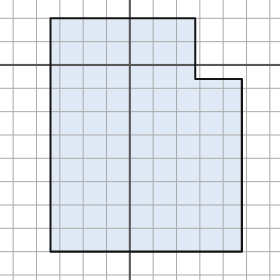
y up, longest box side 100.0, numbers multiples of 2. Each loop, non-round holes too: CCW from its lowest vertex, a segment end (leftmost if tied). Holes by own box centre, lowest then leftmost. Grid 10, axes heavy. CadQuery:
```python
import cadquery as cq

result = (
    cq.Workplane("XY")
    .moveTo(-34.0, -80.0)
    .lineTo(48.0, -80.0)
    .lineTo(48.0, -6.0)
    .lineTo(28.0, -6.0)
    .lineTo(28.0, 20.0)
    .lineTo(-34.0, 20.0)
    .close()
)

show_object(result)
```